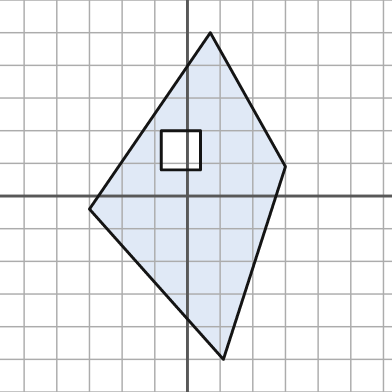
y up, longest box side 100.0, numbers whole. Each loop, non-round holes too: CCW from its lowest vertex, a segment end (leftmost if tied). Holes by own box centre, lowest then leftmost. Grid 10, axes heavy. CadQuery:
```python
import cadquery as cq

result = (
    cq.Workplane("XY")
    .moveTo(11.0, -50.0)
    .lineTo(30.0, 9.0)
    .lineTo(7.0, 50.0)
    .lineTo(-30.0, -4.0)
    .close()
    .moveTo(-8.0, 8.0)
    .lineTo(4.0, 8.0)
    .lineTo(4.0, 20.0)
    .lineTo(-8.0, 20.0)
    .close()
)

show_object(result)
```